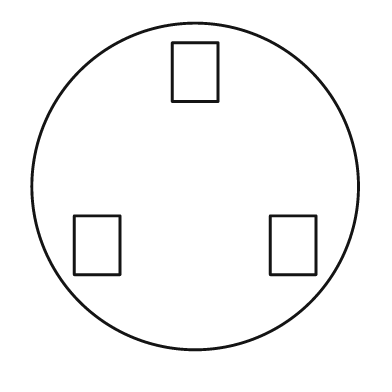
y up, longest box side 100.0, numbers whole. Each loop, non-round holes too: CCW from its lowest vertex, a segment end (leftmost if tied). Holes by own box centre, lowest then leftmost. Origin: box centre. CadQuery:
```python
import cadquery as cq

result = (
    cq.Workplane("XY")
    .moveTo(0.0, 0.0)
    .circle(50.0)
    .moveTo(-37.0, -27.0)
    .lineTo(-23.0, -27.0)
    .lineTo(-23.0, -9.0)
    .lineTo(-37.0, -9.0)
    .close()
    .moveTo(23.0, -27.0)
    .lineTo(37.0, -27.0)
    .lineTo(37.0, -9.0)
    .lineTo(23.0, -9.0)
    .close()
    .moveTo(-7.0, 26.0)
    .lineTo(7.0, 26.0)
    .lineTo(7.0, 44.0)
    .lineTo(-7.0, 44.0)
    .close()
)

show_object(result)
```